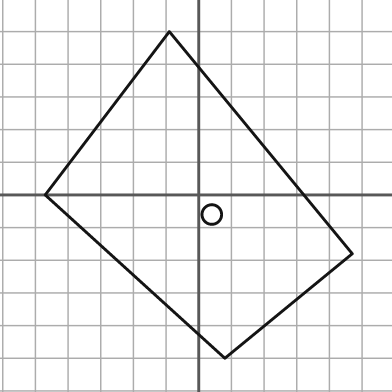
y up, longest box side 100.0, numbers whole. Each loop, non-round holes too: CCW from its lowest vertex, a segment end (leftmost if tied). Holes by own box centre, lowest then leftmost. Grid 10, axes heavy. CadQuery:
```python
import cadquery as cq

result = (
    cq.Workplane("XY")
    .moveTo(8.0, -50.0)
    .lineTo(47.0, -18.0)
    .lineTo(-9.0, 50.0)
    .lineTo(-47.0, 0.0)
    .close()
    .moveTo(4.0, -6.0)
    .circle(3.0)
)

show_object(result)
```